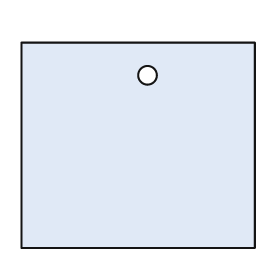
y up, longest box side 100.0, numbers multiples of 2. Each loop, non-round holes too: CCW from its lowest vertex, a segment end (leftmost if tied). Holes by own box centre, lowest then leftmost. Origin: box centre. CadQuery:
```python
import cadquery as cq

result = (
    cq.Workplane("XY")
    .moveTo(-50.0, -44.0)
    .lineTo(50.0, -44.0)
    .lineTo(50.0, 44.0)
    .lineTo(-50.0, 44.0)
    .close()
    .moveTo(4.0, 30.0)
    .circle(4.0)
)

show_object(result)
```